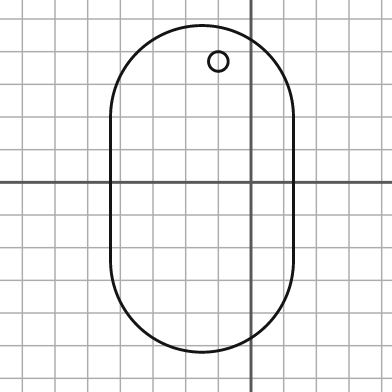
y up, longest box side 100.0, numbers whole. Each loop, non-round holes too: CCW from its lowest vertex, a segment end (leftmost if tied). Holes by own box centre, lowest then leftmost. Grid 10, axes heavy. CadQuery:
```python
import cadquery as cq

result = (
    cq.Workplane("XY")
    .moveTo(-43.0, -24.0)
    .threePointArc((-15.0, -52.0), (13.0, -24.0))
    .lineTo(13.0, 20.0)
    .threePointArc((-15.0, 48.0), (-43.0, 20.0))
    .close()
    .moveTo(-10.0, 37.0)
    .circle(3.0)
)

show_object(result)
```